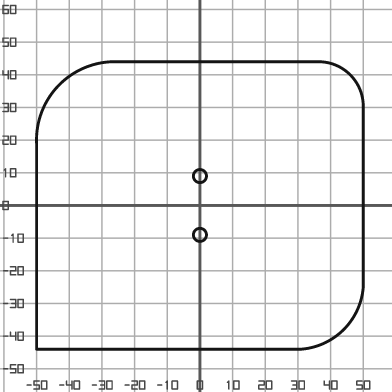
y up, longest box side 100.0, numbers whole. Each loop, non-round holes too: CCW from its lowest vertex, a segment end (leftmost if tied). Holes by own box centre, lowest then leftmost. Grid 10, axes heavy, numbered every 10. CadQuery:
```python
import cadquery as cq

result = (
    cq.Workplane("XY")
    .moveTo(-50.0, -44.0)
    .lineTo(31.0, -44.0)
    .threePointArc((44.0, -38.0), (50.0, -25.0))
    .lineTo(50.0, 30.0)
    .threePointArc((46.0, 40.0), (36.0, 44.0))
    .lineTo(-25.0, 44.0)
    .threePointArc((-43.0, 37.0), (-50.0, 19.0))
    .close()
    .moveTo(0.0, -9.0)
    .circle(2.0)
    .moveTo(0.0, 9.0)
    .circle(2.0)
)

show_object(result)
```